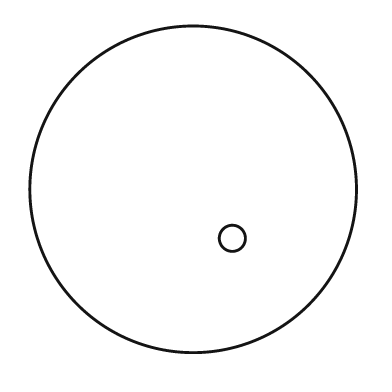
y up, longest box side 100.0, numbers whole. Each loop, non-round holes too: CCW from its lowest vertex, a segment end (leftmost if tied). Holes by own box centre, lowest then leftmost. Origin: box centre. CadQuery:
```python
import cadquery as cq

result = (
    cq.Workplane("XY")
    .moveTo(0.0, 0.0)
    .circle(50.0)
    .moveTo(12.0, -15.0)
    .circle(4.0)
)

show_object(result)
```